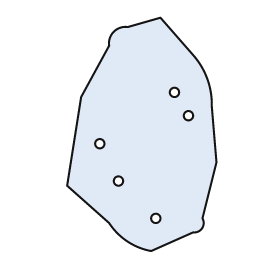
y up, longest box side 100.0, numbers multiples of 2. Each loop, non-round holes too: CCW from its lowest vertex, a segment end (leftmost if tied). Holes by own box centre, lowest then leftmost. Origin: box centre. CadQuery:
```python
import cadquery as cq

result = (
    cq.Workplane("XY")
    .moveTo(4.0, -50.0)
    .lineTo(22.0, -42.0)
    .threePointArc((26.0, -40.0), (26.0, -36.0))
    .lineTo(32.0, -12.0)
    .lineTo(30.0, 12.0)
    .threePointArc((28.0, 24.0), (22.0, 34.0))
    .lineTo(8.0, 50.0)
    .lineTo(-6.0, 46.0)
    .threePointArc((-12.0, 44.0), (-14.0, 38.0))
    .lineTo(-26.0, 16.0)
    .lineTo(-32.0, -22.0)
    .lineTo(-14.0, -38.0)
    .threePointArc((-6.0, -46.0), (4.0, -50.0))
    .close()
    .moveTo(6.0, -36.0)
    .circle(2.0)
    .moveTo(-10.0, -20.0)
    .circle(2.0)
    .moveTo(-18.0, -4.0)
    .circle(2.0)
    .moveTo(20.0, 8.0)
    .circle(2.0)
    .moveTo(14.0, 18.0)
    .circle(2.0)
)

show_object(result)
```